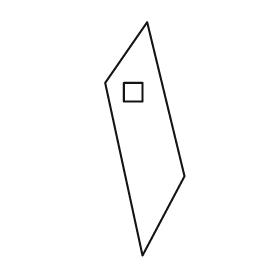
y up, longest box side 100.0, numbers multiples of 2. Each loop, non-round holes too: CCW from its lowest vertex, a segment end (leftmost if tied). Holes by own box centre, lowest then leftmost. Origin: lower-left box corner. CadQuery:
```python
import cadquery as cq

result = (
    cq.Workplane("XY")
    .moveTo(16.0, 0.0)
    .lineTo(34.0, 34.0)
    .lineTo(18.0, 100.0)
    .lineTo(0.0, 74.0)
    .close()
    .moveTo(8.0, 66.0)
    .lineTo(16.0, 66.0)
    .lineTo(16.0, 74.0)
    .lineTo(8.0, 74.0)
    .close()
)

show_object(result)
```